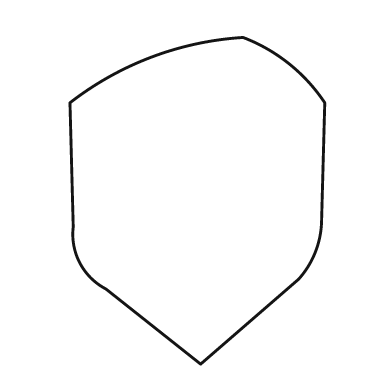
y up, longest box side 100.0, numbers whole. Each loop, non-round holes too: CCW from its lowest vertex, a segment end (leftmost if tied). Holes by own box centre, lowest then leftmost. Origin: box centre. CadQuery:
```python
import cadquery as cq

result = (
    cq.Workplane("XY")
    .moveTo(1.0, -50.0)
    .lineTo(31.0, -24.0)
    .threePointArc((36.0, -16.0), (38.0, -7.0))
    .lineTo(39.0, 30.0)
    .threePointArc((28.0, 42.0), (14.0, 50.0))
    .threePointArc((-14.0, 44.0), (-39.0, 30.0))
    .lineTo(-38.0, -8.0)
    .threePointArc((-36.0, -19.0), (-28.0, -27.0))
    .close()
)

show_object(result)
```